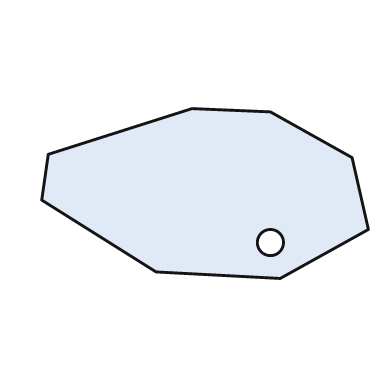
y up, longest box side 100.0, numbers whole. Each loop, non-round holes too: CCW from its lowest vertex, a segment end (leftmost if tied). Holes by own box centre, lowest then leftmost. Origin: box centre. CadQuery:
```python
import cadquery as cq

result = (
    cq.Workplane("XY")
    .moveTo(23.0, -26.0)
    .lineTo(50.0, -11.0)
    .lineTo(45.0, 11.0)
    .lineTo(20.0, 25.0)
    .lineTo(-4.0, 26.0)
    .lineTo(-48.0, 12.0)
    .lineTo(-50.0, -2.0)
    .lineTo(-15.0, -24.0)
    .close()
    .moveTo(20.0, -15.0)
    .circle(4.0)
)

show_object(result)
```